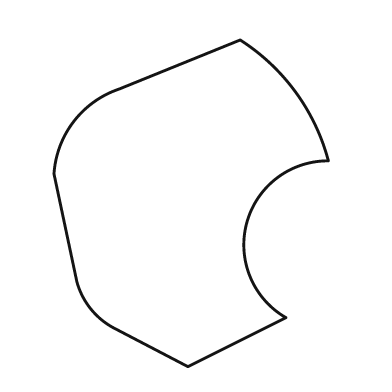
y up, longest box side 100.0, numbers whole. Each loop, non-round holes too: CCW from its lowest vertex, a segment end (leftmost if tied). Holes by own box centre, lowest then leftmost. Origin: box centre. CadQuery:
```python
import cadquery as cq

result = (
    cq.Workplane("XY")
    .moveTo(-1.0, -50.0)
    .lineTo(29.0, -35.0)
    .threePointArc((17.0, -6.0), (42.0, 13.0))
    .threePointArc((32.0, 34.0), (15.0, 50.0))
    .lineTo(-22.0, 35.0)
    .threePointArc((-36.0, 25.0), (-42.0, 9.0))
    .lineTo(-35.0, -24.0)
    .threePointArc((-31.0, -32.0), (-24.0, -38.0))
    .close()
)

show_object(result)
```